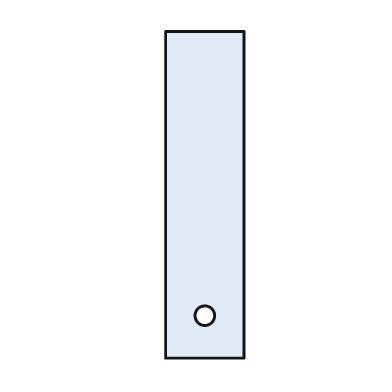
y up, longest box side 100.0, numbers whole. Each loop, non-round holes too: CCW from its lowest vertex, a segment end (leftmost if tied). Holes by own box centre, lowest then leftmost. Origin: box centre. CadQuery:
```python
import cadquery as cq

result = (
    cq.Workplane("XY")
    .moveTo(-12.0, -50.0)
    .lineTo(12.0, -50.0)
    .lineTo(12.0, 50.0)
    .lineTo(-12.0, 50.0)
    .close()
    .moveTo(0.0, -37.0)
    .circle(3.0)
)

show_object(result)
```